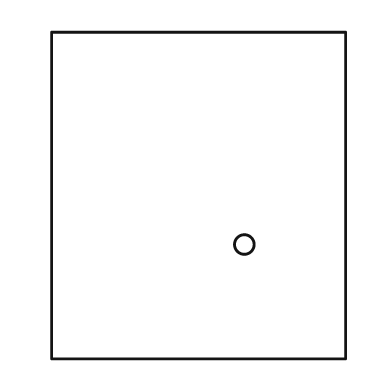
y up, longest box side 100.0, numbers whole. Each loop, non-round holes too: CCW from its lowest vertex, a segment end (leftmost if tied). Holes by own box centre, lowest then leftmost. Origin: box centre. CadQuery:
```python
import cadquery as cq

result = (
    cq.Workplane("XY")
    .moveTo(-45.0, -50.0)
    .lineTo(45.0, -50.0)
    .lineTo(45.0, 50.0)
    .lineTo(-45.0, 50.0)
    .close()
    .moveTo(14.0, -15.0)
    .circle(3.0)
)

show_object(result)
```